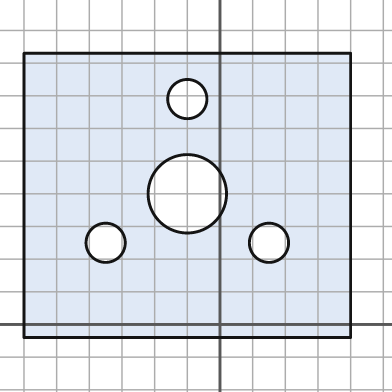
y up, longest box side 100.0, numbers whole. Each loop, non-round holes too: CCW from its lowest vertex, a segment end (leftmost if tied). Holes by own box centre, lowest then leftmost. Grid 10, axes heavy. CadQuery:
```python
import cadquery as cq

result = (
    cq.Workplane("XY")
    .moveTo(-60.0, -4.0)
    .lineTo(40.0, -4.0)
    .lineTo(40.0, 83.0)
    .lineTo(-60.0, 83.0)
    .close()
    .moveTo(-35.0, 25.0)
    .circle(6.0)
    .moveTo(15.0, 25.0)
    .circle(6.0)
    .moveTo(-10.0, 40.0)
    .circle(12.0)
    .moveTo(-10.0, 69.0)
    .circle(6.0)
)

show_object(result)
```